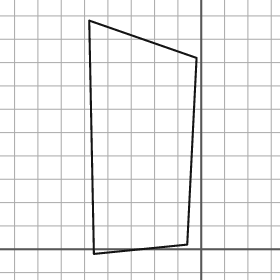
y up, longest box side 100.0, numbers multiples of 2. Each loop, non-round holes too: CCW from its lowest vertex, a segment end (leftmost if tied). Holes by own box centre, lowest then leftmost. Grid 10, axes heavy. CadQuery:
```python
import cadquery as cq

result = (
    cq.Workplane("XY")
    .moveTo(-46.0, -2.0)
    .lineTo(-6.0, 2.0)
    .lineTo(-2.0, 82.0)
    .lineTo(-48.0, 98.0)
    .close()
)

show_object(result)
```